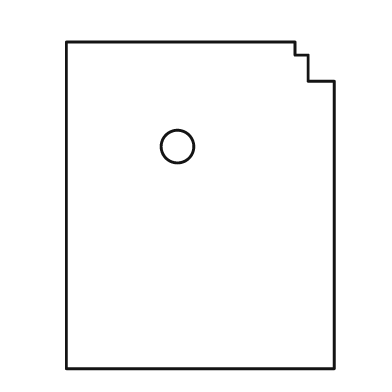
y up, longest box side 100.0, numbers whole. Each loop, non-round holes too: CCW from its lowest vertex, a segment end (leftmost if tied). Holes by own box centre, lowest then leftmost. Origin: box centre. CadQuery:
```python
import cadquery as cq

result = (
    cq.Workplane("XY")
    .moveTo(-41.0, -50.0)
    .lineTo(41.0, -50.0)
    .lineTo(41.0, 38.0)
    .lineTo(33.0, 38.0)
    .lineTo(33.0, 46.0)
    .lineTo(29.0, 46.0)
    .lineTo(29.0, 50.0)
    .lineTo(-41.0, 50.0)
    .close()
    .moveTo(-7.0, 18.0)
    .circle(5.0)
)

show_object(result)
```